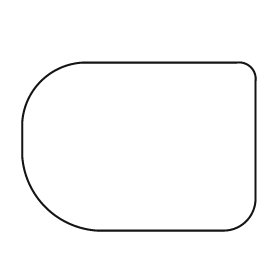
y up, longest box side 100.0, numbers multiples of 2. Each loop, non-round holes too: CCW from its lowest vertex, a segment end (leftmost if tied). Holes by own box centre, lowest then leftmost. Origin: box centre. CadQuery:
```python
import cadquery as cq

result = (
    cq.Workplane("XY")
    .moveTo(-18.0, -36.0)
    .lineTo(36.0, -36.0)
    .threePointArc((46.0, -32.0), (50.0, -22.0))
    .lineTo(50.0, 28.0)
    .threePointArc((48.0, 34.0), (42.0, 36.0))
    .lineTo(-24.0, 36.0)
    .threePointArc((-42.0, 28.0), (-50.0, 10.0))
    .lineTo(-50.0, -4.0)
    .threePointArc((-40.0, -26.0), (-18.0, -36.0))
    .close()
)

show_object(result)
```